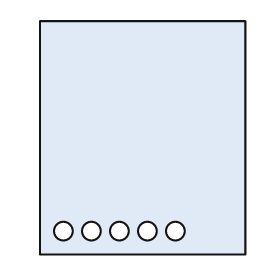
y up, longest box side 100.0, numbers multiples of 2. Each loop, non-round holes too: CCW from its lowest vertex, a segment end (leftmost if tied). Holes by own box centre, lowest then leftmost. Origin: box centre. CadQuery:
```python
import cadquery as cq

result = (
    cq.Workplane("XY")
    .moveTo(-44.0, -50.0)
    .lineTo(44.0, -50.0)
    .lineTo(44.0, 50.0)
    .lineTo(-44.0, 50.0)
    .close()
    .moveTo(-34.0, -40.0)
    .circle(4.0)
    .moveTo(-22.0, -40.0)
    .circle(4.0)
    .moveTo(-10.0, -40.0)
    .circle(4.0)
    .moveTo(2.0, -40.0)
    .circle(4.0)
    .moveTo(14.0, -40.0)
    .circle(4.0)
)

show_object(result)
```